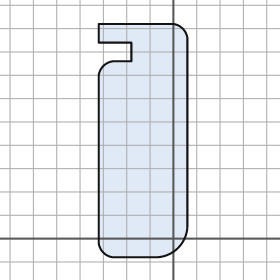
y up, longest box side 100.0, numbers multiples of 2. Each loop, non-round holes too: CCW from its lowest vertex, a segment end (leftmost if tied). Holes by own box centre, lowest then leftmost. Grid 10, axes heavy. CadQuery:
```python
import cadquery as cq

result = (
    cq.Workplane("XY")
    .moveTo(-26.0, -8.0)
    .lineTo(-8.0, -8.0)
    .threePointArc((2.0, -4.0), (6.0, 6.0))
    .lineTo(6.0, 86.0)
    .threePointArc((4.0, 90.0), (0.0, 92.0))
    .lineTo(-32.0, 92.0)
    .lineTo(-32.0, 84.0)
    .lineTo(-18.0, 84.0)
    .lineTo(-18.0, 76.0)
    .lineTo(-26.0, 76.0)
    .threePointArc((-30.0, 74.0), (-32.0, 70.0))
    .lineTo(-32.0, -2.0)
    .threePointArc((-30.0, -6.0), (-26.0, -8.0))
    .close()
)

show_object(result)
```